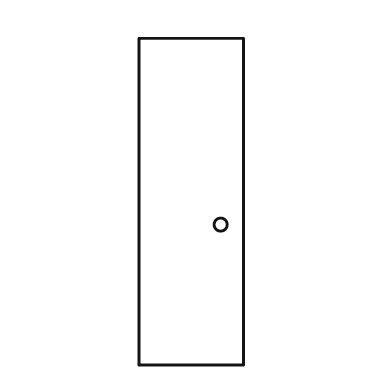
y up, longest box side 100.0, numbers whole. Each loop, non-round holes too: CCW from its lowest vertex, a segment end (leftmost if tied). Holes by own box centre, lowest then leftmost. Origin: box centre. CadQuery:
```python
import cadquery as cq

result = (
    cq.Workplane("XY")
    .moveTo(-16.0, -50.0)
    .lineTo(16.0, -50.0)
    .lineTo(16.0, 50.0)
    .lineTo(-16.0, 50.0)
    .close()
    .moveTo(9.0, -7.0)
    .circle(2.0)
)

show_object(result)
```